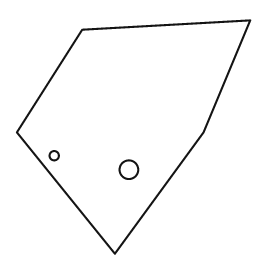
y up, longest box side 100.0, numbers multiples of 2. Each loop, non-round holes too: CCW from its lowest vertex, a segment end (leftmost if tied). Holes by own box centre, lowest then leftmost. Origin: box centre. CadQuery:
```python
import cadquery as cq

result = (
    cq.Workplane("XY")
    .moveTo(-8.0, -50.0)
    .lineTo(30.0, 2.0)
    .lineTo(50.0, 50.0)
    .lineTo(-22.0, 46.0)
    .lineTo(-50.0, 2.0)
    .close()
    .moveTo(-2.0, -14.0)
    .circle(4.0)
    .moveTo(-34.0, -8.0)
    .circle(2.0)
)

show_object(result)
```